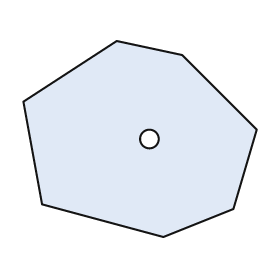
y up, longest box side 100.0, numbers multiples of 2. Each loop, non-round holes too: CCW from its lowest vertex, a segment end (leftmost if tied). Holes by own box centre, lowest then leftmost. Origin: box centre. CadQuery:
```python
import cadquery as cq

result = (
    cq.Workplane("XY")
    .moveTo(10.0, -42.0)
    .lineTo(40.0, -30.0)
    .lineTo(50.0, 4.0)
    .lineTo(18.0, 36.0)
    .lineTo(-10.0, 42.0)
    .lineTo(-50.0, 16.0)
    .lineTo(-42.0, -28.0)
    .close()
    .moveTo(4.0, 0.0)
    .circle(4.0)
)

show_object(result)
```